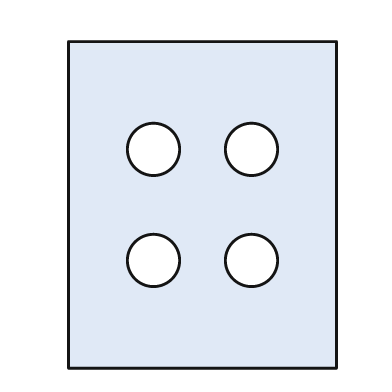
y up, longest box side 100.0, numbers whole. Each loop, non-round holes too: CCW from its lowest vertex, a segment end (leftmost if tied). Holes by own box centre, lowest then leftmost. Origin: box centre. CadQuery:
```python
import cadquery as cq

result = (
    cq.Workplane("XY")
    .moveTo(-41.0, -50.0)
    .lineTo(41.0, -50.0)
    .lineTo(41.0, 50.0)
    .lineTo(-41.0, 50.0)
    .close()
    .moveTo(-15.0, -17.0)
    .circle(8.0)
    .moveTo(15.0, -17.0)
    .circle(8.0)
    .moveTo(-15.0, 17.0)
    .circle(8.0)
    .moveTo(15.0, 17.0)
    .circle(8.0)
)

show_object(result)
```